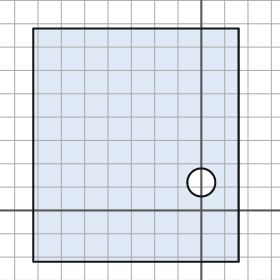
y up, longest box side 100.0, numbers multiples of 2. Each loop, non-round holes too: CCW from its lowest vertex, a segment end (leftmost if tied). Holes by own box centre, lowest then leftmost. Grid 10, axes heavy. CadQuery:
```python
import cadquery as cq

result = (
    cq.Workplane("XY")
    .moveTo(-72.0, -22.0)
    .lineTo(16.0, -22.0)
    .lineTo(16.0, 78.0)
    .lineTo(-72.0, 78.0)
    .close()
    .moveTo(0.0, 12.0)
    .circle(6.0)
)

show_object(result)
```